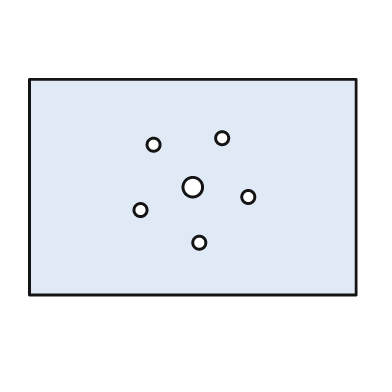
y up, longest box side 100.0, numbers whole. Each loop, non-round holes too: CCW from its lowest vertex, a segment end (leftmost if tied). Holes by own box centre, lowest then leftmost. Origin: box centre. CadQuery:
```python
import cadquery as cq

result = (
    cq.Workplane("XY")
    .moveTo(-50.0, -33.0)
    .lineTo(50.0, -33.0)
    .lineTo(50.0, 33.0)
    .lineTo(-50.0, 33.0)
    .close()
    .moveTo(2.0, -17.0)
    .circle(2.0)
    .moveTo(-16.0, -7.0)
    .circle(2.0)
    .moveTo(17.0, -3.0)
    .circle(2.0)
    .moveTo(0.0, 0.0)
    .circle(3.0)
    .moveTo(-12.0, 13.0)
    .circle(2.0)
    .moveTo(9.0, 15.0)
    .circle(2.0)
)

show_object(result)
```